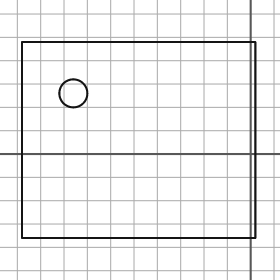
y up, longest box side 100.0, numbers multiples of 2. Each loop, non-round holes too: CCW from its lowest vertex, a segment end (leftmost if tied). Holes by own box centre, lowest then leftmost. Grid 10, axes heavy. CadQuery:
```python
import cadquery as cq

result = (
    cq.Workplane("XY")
    .moveTo(-98.0, -36.0)
    .lineTo(2.0, -36.0)
    .lineTo(2.0, 48.0)
    .lineTo(-98.0, 48.0)
    .close()
    .moveTo(-76.0, 26.0)
    .circle(6.0)
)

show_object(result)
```